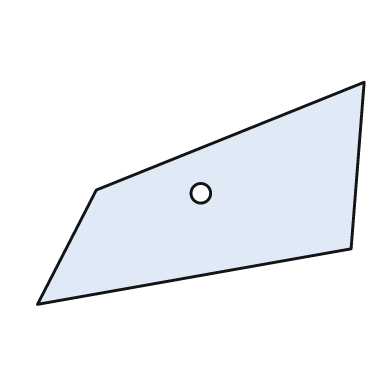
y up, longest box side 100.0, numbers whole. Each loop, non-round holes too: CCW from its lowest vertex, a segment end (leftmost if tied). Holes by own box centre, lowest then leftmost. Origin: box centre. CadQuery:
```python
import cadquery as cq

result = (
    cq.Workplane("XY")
    .moveTo(-50.0, -34.0)
    .lineTo(46.0, -17.0)
    .lineTo(50.0, 34.0)
    .lineTo(-32.0, 1.0)
    .close()
    .moveTo(0.0, 0.0)
    .circle(3.0)
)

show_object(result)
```